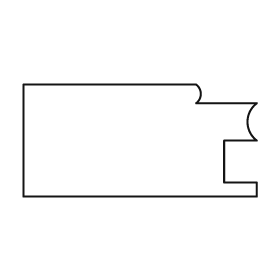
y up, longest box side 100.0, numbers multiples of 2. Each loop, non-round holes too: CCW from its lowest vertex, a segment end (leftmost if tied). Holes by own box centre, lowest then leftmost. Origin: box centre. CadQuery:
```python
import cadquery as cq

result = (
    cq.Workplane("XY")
    .moveTo(-50.0, -24.0)
    .lineTo(50.0, -24.0)
    .lineTo(50.0, -18.0)
    .lineTo(36.0, -18.0)
    .lineTo(36.0, 0.0)
    .lineTo(50.0, 0.0)
    .threePointArc((46.0, 8.0), (50.0, 16.0))
    .lineTo(24.0, 16.0)
    .threePointArc((26.0, 20.0), (24.0, 24.0))
    .lineTo(-50.0, 24.0)
    .close()
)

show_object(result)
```